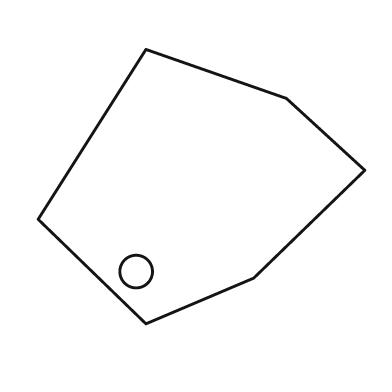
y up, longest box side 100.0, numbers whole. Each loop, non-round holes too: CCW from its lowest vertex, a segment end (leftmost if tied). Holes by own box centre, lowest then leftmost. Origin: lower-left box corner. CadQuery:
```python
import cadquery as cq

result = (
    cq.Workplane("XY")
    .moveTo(33.0, 0.0)
    .lineTo(66.0, 14.0)
    .lineTo(100.0, 47.0)
    .lineTo(76.0, 69.0)
    .lineTo(33.0, 84.0)
    .lineTo(0.0, 32.0)
    .close()
    .moveTo(30.0, 16.0)
    .circle(5.0)
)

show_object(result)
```